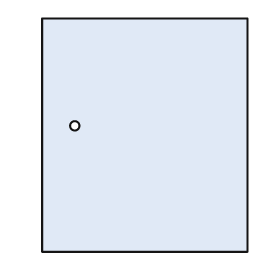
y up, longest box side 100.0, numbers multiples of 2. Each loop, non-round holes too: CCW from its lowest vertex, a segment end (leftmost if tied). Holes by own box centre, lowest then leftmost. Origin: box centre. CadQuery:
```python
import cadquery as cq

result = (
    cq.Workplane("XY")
    .moveTo(-44.0, -50.0)
    .lineTo(44.0, -50.0)
    .lineTo(44.0, 50.0)
    .lineTo(-44.0, 50.0)
    .close()
    .moveTo(-30.0, 4.0)
    .circle(2.0)
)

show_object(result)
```